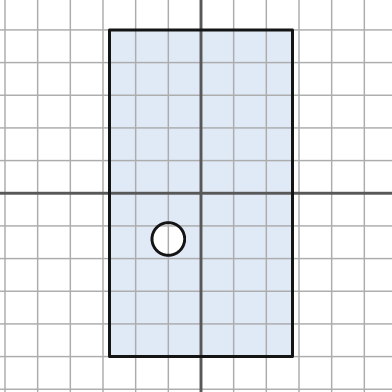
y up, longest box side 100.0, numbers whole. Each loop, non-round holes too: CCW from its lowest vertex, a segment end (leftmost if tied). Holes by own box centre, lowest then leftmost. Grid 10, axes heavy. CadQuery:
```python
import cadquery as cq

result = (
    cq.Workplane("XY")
    .moveTo(-28.0, -50.0)
    .lineTo(28.0, -50.0)
    .lineTo(28.0, 50.0)
    .lineTo(-28.0, 50.0)
    .close()
    .moveTo(-10.0, -14.0)
    .circle(5.0)
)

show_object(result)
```